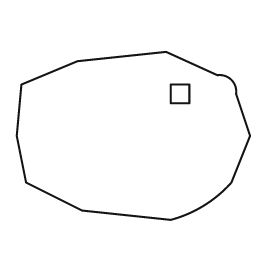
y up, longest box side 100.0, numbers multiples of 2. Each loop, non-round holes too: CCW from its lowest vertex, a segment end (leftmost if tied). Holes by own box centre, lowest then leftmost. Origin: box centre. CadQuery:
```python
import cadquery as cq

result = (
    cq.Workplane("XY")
    .moveTo(16.0, -36.0)
    .threePointArc((30.0, -30.0), (42.0, -20.0))
    .lineTo(50.0, 0.0)
    .lineTo(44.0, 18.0)
    .threePointArc((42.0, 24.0), (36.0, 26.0))
    .lineTo(14.0, 36.0)
    .lineTo(-24.0, 32.0)
    .lineTo(-48.0, 22.0)
    .lineTo(-50.0, 0.0)
    .lineTo(-46.0, -20.0)
    .lineTo(-22.0, -32.0)
    .close()
    .moveTo(16.0, 14.0)
    .lineTo(24.0, 14.0)
    .lineTo(24.0, 22.0)
    .lineTo(16.0, 22.0)
    .close()
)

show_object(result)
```